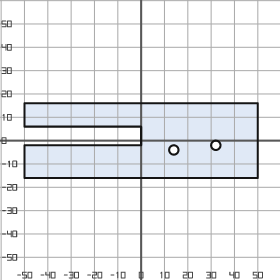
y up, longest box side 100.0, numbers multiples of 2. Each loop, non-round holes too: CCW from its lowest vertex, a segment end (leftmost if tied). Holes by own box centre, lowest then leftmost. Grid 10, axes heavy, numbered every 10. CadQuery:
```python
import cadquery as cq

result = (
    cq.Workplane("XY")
    .moveTo(-50.0, -16.0)
    .lineTo(50.0, -16.0)
    .lineTo(50.0, 16.0)
    .lineTo(-50.0, 16.0)
    .lineTo(-50.0, 6.0)
    .lineTo(0.0, 6.0)
    .lineTo(0.0, -2.0)
    .lineTo(-50.0, -2.0)
    .close()
    .moveTo(14.0, -4.0)
    .circle(2.0)
    .moveTo(32.0, -2.0)
    .circle(2.0)
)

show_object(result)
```